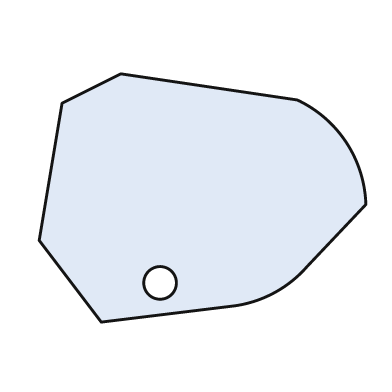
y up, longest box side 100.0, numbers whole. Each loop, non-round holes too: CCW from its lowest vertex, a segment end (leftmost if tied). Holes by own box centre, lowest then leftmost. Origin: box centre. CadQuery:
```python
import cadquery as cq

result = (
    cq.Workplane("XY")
    .moveTo(-31.0, -38.0)
    .lineTo(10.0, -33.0)
    .threePointArc((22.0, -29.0), (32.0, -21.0))
    .lineTo(50.0, -2.0)
    .threePointArc((44.0, 17.0), (29.0, 30.0))
    .lineTo(-25.0, 38.0)
    .lineTo(-43.0, 29.0)
    .lineTo(-50.0, -13.0)
    .close()
    .moveTo(-13.0, -26.0)
    .circle(5.0)
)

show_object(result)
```